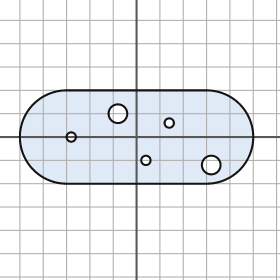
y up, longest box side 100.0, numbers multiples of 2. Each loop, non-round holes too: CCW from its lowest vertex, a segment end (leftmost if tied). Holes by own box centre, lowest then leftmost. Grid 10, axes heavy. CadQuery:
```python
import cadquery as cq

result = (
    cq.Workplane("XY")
    .moveTo(-30.0, -20.0)
    .lineTo(30.0, -20.0)
    .threePointArc((50.0, 0.0), (30.0, 20.0))
    .lineTo(-30.0, 20.0)
    .threePointArc((-50.0, 0.0), (-30.0, -20.0))
    .close()
    .moveTo(32.0, -12.0)
    .circle(4.0)
    .moveTo(4.0, -10.0)
    .circle(2.0)
    .moveTo(-28.0, 0.0)
    .circle(2.0)
    .moveTo(14.0, 6.0)
    .circle(2.0)
    .moveTo(-8.0, 10.0)
    .circle(4.0)
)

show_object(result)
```